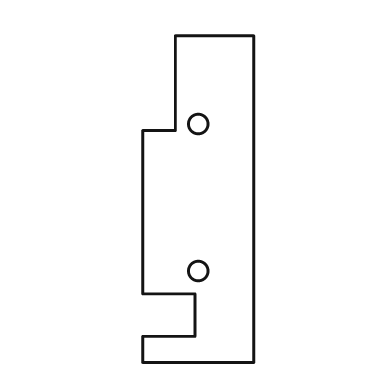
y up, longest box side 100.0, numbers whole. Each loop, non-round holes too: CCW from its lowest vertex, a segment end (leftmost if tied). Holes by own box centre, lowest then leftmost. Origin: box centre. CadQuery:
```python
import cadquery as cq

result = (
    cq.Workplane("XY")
    .moveTo(-17.0, -50.0)
    .lineTo(17.0, -50.0)
    .lineTo(17.0, 50.0)
    .lineTo(-7.0, 50.0)
    .lineTo(-7.0, 21.0)
    .lineTo(-17.0, 21.0)
    .lineTo(-17.0, -29.0)
    .lineTo(-1.0, -29.0)
    .lineTo(-1.0, -42.0)
    .lineTo(-17.0, -42.0)
    .close()
    .moveTo(0.0, -22.0)
    .circle(3.0)
    .moveTo(0.0, 23.0)
    .circle(3.0)
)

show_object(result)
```